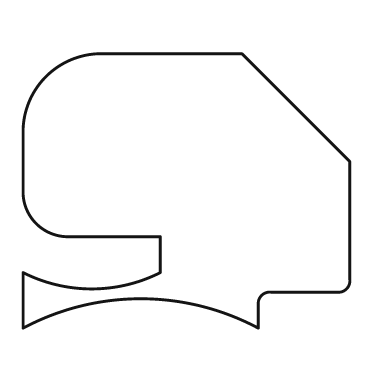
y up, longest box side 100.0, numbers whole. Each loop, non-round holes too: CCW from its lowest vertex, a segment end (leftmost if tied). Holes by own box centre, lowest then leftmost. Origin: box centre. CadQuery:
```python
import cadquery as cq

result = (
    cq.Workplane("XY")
    .moveTo(-50.0, -42.0)
    .threePointArc((-14.0, -33.0), (22.0, -42.0))
    .lineTo(22.0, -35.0)
    .threePointArc((23.0, -32.0), (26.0, -31.0))
    .lineTo(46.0, -31.0)
    .threePointArc((49.0, -30.0), (50.0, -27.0))
    .lineTo(50.0, 9.0)
    .lineTo(17.0, 42.0)
    .lineTo(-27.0, 42.0)
    .threePointArc((-43.0, 35.0), (-50.0, 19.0))
    .lineTo(-50.0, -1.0)
    .threePointArc((-46.0, -10.0), (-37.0, -14.0))
    .lineTo(-8.0, -14.0)
    .lineTo(-8.0, -25.0)
    .threePointArc((-29.0, -30.0), (-50.0, -25.0))
    .close()
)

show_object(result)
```